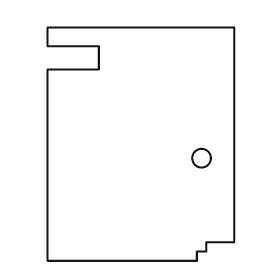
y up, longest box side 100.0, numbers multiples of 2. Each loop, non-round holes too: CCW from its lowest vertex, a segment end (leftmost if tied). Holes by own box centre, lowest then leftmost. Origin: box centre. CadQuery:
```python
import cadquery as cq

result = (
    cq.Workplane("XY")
    .moveTo(-40.0, -50.0)
    .lineTo(24.0, -50.0)
    .lineTo(24.0, -46.0)
    .lineTo(28.0, -46.0)
    .lineTo(28.0, -42.0)
    .lineTo(40.0, -42.0)
    .lineTo(40.0, 50.0)
    .lineTo(-40.0, 50.0)
    .lineTo(-40.0, 42.0)
    .lineTo(-18.0, 42.0)
    .lineTo(-18.0, 32.0)
    .lineTo(-40.0, 32.0)
    .close()
    .moveTo(26.0, -6.0)
    .circle(4.0)
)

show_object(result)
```